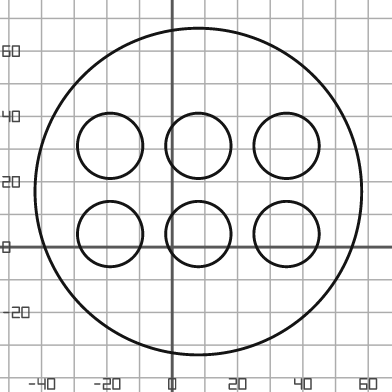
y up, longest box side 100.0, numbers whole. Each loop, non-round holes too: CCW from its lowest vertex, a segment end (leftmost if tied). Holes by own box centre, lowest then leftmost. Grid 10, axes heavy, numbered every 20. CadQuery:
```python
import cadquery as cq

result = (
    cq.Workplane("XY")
    .moveTo(8.0, 17.0)
    .circle(50.0)
    .moveTo(-19.0, 4.0)
    .circle(10.0)
    .moveTo(8.0, 4.0)
    .circle(10.0)
    .moveTo(35.0, 4.0)
    .circle(10.0)
    .moveTo(-19.0, 31.0)
    .circle(10.0)
    .moveTo(8.0, 31.0)
    .circle(10.0)
    .moveTo(35.0, 31.0)
    .circle(10.0)
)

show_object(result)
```